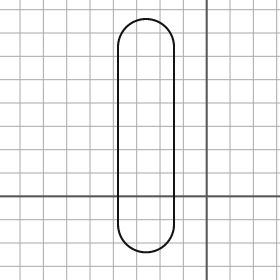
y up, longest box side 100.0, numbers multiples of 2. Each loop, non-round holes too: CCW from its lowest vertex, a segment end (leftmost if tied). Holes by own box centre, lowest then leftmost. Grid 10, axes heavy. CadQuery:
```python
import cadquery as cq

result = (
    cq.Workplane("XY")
    .moveTo(-38.0, -12.0)
    .threePointArc((-26.0, -24.0), (-14.0, -12.0))
    .lineTo(-14.0, 64.0)
    .threePointArc((-26.0, 76.0), (-38.0, 64.0))
    .close()
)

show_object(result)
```